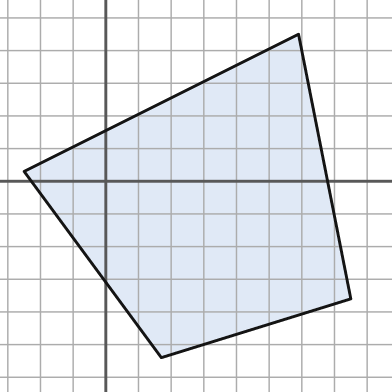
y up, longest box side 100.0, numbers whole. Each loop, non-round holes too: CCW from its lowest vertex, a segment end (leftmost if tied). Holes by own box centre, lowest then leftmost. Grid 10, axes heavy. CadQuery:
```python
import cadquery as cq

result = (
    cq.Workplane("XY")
    .moveTo(17.0, -54.0)
    .lineTo(75.0, -36.0)
    .lineTo(59.0, 45.0)
    .lineTo(-25.0, 3.0)
    .close()
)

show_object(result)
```